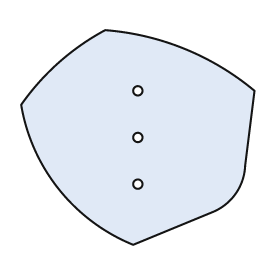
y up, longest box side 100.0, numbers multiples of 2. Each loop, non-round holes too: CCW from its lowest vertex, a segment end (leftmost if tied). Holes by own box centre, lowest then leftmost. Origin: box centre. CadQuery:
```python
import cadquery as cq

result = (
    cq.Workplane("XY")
    .moveTo(-2.0, -46.0)
    .lineTo(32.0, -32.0)
    .threePointArc((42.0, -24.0), (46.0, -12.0))
    .lineTo(50.0, 20.0)
    .threePointArc((20.0, 38.0), (-14.0, 46.0))
    .threePointArc((-34.0, 32.0), (-50.0, 14.0))
    .threePointArc((-34.0, -22.0), (-2.0, -46.0))
    .close()
    .moveTo(0.0, -20.0)
    .circle(2.0)
    .moveTo(0.0, 0.0)
    .circle(2.0)
    .moveTo(0.0, 20.0)
    .circle(2.0)
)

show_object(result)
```